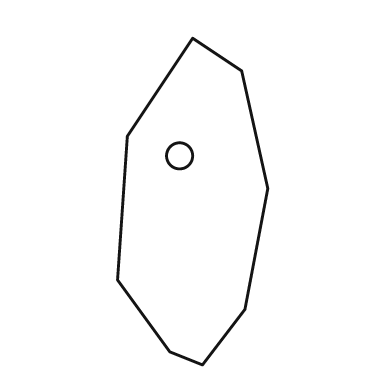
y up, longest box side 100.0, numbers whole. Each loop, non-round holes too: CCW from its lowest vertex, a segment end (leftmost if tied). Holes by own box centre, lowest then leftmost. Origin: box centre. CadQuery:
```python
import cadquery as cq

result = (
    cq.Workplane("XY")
    .moveTo(3.0, -50.0)
    .lineTo(16.0, -33.0)
    .lineTo(23.0, 4.0)
    .lineTo(15.0, 40.0)
    .lineTo(0.0, 50.0)
    .lineTo(-20.0, 20.0)
    .lineTo(-23.0, -24.0)
    .lineTo(-7.0, -46.0)
    .close()
    .moveTo(-4.0, 14.0)
    .circle(4.0)
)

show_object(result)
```